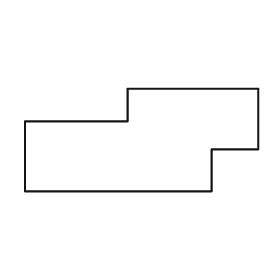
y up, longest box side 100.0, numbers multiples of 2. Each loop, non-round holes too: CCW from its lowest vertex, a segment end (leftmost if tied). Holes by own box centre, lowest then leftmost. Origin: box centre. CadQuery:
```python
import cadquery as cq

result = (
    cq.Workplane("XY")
    .moveTo(-50.0, -22.0)
    .lineTo(30.0, -22.0)
    .lineTo(30.0, -4.0)
    .lineTo(50.0, -4.0)
    .lineTo(50.0, 22.0)
    .lineTo(-6.0, 22.0)
    .lineTo(-6.0, 8.0)
    .lineTo(-50.0, 8.0)
    .close()
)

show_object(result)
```